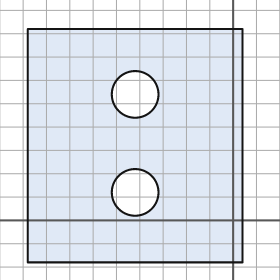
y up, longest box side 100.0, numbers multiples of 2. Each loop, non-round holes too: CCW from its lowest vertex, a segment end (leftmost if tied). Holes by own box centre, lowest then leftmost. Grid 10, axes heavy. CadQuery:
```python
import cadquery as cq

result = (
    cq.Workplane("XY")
    .moveTo(-88.0, -18.0)
    .lineTo(4.0, -18.0)
    .lineTo(4.0, 82.0)
    .lineTo(-88.0, 82.0)
    .close()
    .moveTo(-42.0, 12.0)
    .circle(10.0)
    .moveTo(-42.0, 54.0)
    .circle(10.0)
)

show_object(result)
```